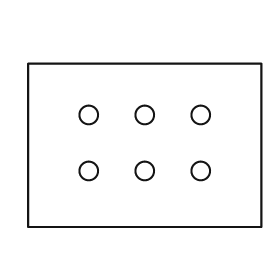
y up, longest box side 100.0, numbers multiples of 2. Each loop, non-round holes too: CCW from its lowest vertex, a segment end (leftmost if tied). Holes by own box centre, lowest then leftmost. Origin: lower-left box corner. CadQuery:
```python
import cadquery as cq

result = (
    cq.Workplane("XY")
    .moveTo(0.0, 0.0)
    .lineTo(100.0, 0.0)
    .lineTo(100.0, 70.0)
    .lineTo(0.0, 70.0)
    .close()
    .moveTo(26.0, 24.0)
    .circle(4.0)
    .moveTo(50.0, 24.0)
    .circle(4.0)
    .moveTo(74.0, 24.0)
    .circle(4.0)
    .moveTo(26.0, 48.0)
    .circle(4.0)
    .moveTo(50.0, 48.0)
    .circle(4.0)
    .moveTo(74.0, 48.0)
    .circle(4.0)
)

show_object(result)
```